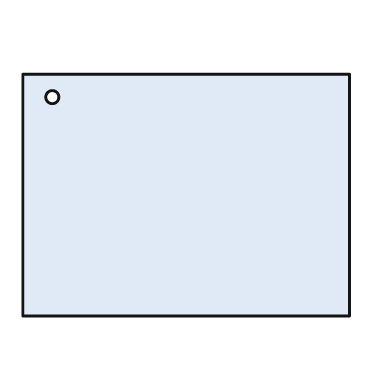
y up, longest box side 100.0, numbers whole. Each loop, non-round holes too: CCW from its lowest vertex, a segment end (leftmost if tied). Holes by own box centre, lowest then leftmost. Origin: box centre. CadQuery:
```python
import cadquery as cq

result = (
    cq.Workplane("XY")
    .moveTo(-50.0, -37.0)
    .lineTo(50.0, -37.0)
    .lineTo(50.0, 37.0)
    .lineTo(-50.0, 37.0)
    .close()
    .moveTo(-41.0, 30.0)
    .circle(2.0)
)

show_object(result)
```